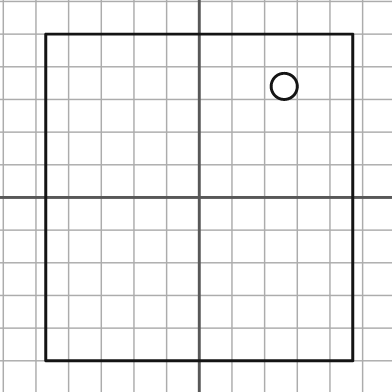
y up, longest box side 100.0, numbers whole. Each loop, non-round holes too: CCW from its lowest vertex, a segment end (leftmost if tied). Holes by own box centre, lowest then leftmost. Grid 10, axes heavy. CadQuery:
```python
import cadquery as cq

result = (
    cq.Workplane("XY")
    .moveTo(-47.0, -50.0)
    .lineTo(47.0, -50.0)
    .lineTo(47.0, 50.0)
    .lineTo(-47.0, 50.0)
    .close()
    .moveTo(26.0, 34.0)
    .circle(4.0)
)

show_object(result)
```